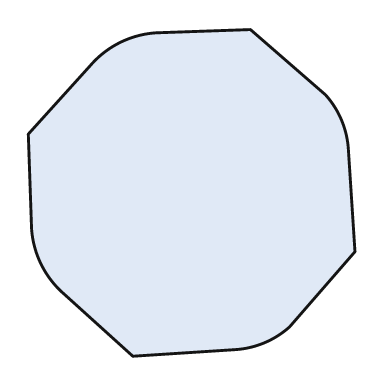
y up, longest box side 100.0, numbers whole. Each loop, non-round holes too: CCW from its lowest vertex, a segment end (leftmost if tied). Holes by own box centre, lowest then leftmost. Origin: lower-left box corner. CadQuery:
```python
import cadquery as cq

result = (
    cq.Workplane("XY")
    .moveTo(32.0, 0.0)
    .lineTo(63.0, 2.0)
    .threePointArc((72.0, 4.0), (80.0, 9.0))
    .lineTo(100.0, 32.0)
    .lineTo(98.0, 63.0)
    .threePointArc((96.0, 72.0), (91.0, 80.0))
    .lineTo(68.0, 100.0)
    .lineTo(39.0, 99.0)
    .threePointArc((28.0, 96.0), (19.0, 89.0))
    .lineTo(0.0, 68.0)
    .lineTo(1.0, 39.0)
    .threePointArc((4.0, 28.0), (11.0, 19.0))
    .close()
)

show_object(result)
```